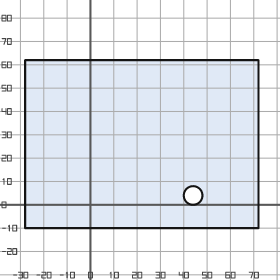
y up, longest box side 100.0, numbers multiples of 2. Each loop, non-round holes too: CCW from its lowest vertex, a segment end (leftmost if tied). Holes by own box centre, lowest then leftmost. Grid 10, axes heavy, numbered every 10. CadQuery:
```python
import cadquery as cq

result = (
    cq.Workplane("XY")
    .moveTo(-28.0, -10.0)
    .lineTo(72.0, -10.0)
    .lineTo(72.0, 62.0)
    .lineTo(-28.0, 62.0)
    .close()
    .moveTo(44.0, 4.0)
    .circle(4.0)
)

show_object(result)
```